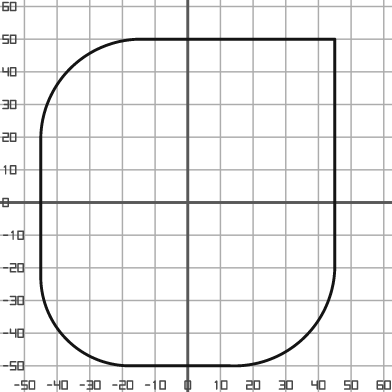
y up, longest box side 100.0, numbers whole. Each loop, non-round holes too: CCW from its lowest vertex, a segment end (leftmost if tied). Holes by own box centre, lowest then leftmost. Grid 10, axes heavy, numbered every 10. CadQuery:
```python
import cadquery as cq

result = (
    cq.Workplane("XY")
    .moveTo(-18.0, -50.0)
    .lineTo(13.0, -50.0)
    .threePointArc((36.0, -41.0), (45.0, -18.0))
    .lineTo(45.0, 50.0)
    .lineTo(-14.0, 50.0)
    .threePointArc((-36.0, 41.0), (-45.0, 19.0))
    .lineTo(-45.0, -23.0)
    .threePointArc((-37.0, -42.0), (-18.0, -50.0))
    .close()
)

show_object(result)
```